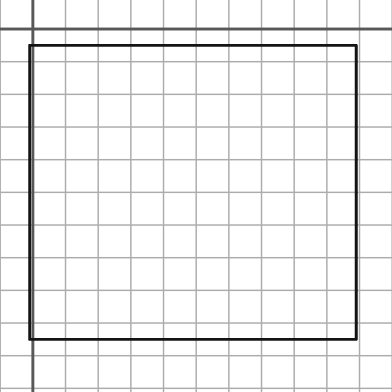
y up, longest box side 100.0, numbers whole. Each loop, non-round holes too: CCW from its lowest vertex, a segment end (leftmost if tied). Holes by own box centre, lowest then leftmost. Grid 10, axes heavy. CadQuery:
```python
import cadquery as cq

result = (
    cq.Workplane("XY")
    .moveTo(-1.0, -95.0)
    .lineTo(99.0, -95.0)
    .lineTo(99.0, -5.0)
    .lineTo(-1.0, -5.0)
    .close()
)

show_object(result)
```